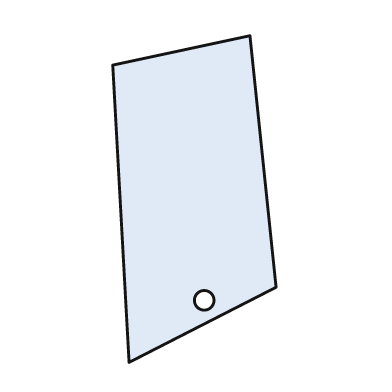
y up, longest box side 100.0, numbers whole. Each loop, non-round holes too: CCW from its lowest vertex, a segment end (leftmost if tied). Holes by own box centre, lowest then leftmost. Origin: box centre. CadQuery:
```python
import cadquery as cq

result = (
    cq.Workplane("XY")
    .moveTo(-20.0, -50.0)
    .lineTo(25.0, -27.0)
    .lineTo(17.0, 50.0)
    .lineTo(-25.0, 41.0)
    .close()
    .moveTo(3.0, -31.0)
    .circle(3.0)
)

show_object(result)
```